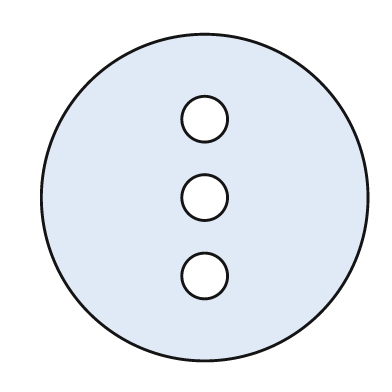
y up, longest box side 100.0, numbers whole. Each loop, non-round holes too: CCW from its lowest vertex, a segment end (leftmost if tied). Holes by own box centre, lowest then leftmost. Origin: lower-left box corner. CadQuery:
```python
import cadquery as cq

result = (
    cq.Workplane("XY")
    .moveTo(50.0, 50.0)
    .circle(50.0)
    .moveTo(50.0, 26.0)
    .circle(7.0)
    .moveTo(50.0, 50.0)
    .circle(7.0)
    .moveTo(50.0, 74.0)
    .circle(7.0)
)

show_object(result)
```